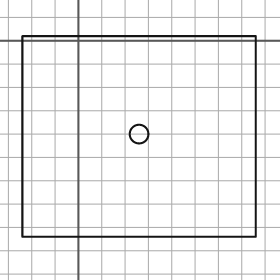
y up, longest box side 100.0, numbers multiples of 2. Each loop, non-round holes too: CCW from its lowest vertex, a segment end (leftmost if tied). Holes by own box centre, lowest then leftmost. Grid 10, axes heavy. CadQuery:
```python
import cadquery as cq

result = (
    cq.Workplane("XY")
    .moveTo(-24.0, -84.0)
    .lineTo(76.0, -84.0)
    .lineTo(76.0, 2.0)
    .lineTo(-24.0, 2.0)
    .close()
    .moveTo(26.0, -40.0)
    .circle(4.0)
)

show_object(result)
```